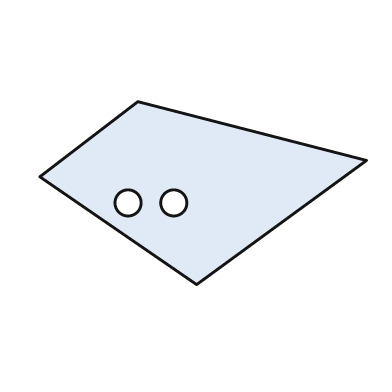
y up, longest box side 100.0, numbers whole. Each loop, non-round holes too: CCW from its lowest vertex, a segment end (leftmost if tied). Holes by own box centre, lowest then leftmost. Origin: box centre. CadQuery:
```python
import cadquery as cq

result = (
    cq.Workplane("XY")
    .moveTo(-2.0, -28.0)
    .lineTo(50.0, 10.0)
    .lineTo(-20.0, 28.0)
    .lineTo(-50.0, 5.0)
    .close()
    .moveTo(-23.0, -3.0)
    .circle(4.0)
    .moveTo(-9.0, -3.0)
    .circle(4.0)
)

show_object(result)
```